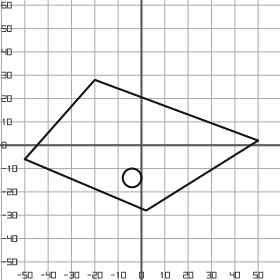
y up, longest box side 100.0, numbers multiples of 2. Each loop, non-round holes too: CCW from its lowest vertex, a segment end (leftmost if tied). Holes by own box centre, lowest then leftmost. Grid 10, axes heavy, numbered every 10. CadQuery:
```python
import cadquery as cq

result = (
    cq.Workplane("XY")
    .moveTo(2.0, -28.0)
    .lineTo(50.0, 2.0)
    .lineTo(-20.0, 28.0)
    .lineTo(-50.0, -6.0)
    .close()
    .moveTo(-4.0, -14.0)
    .circle(4.0)
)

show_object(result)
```